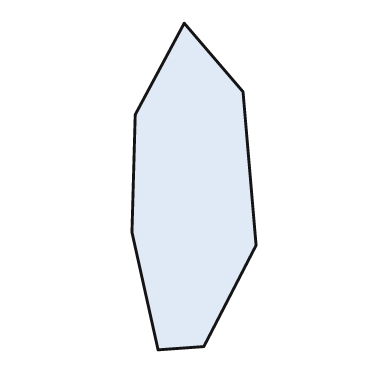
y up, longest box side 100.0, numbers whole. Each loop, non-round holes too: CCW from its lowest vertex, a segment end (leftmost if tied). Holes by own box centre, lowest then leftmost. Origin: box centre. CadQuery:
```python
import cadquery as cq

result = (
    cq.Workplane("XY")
    .moveTo(-11.0, -50.0)
    .lineTo(3.0, -49.0)
    .lineTo(19.0, -18.0)
    .lineTo(15.0, 29.0)
    .lineTo(-3.0, 50.0)
    .lineTo(-18.0, 22.0)
    .lineTo(-19.0, -14.0)
    .close()
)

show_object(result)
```